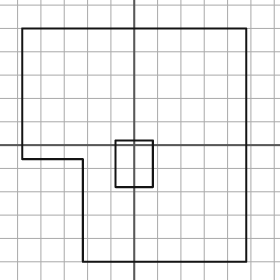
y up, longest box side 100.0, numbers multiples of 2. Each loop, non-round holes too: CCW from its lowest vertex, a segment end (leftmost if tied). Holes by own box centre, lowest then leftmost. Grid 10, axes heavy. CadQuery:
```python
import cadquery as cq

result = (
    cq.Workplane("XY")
    .moveTo(-22.0, -50.0)
    .lineTo(48.0, -50.0)
    .lineTo(48.0, 50.0)
    .lineTo(-48.0, 50.0)
    .lineTo(-48.0, -6.0)
    .lineTo(-22.0, -6.0)
    .close()
    .moveTo(-8.0, -18.0)
    .lineTo(8.0, -18.0)
    .lineTo(8.0, 2.0)
    .lineTo(-8.0, 2.0)
    .close()
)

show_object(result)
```